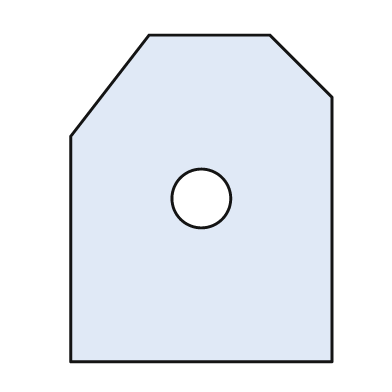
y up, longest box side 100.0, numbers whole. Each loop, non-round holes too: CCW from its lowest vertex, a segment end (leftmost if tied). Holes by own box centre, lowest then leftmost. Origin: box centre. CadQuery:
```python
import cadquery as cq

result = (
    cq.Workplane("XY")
    .moveTo(-40.0, -50.0)
    .lineTo(40.0, -50.0)
    .lineTo(40.0, 31.0)
    .lineTo(21.0, 50.0)
    .lineTo(-16.0, 50.0)
    .lineTo(-40.0, 19.0)
    .close()
    .moveTo(0.0, 0.0)
    .circle(9.0)
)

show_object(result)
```